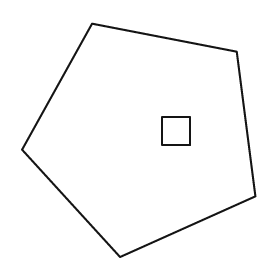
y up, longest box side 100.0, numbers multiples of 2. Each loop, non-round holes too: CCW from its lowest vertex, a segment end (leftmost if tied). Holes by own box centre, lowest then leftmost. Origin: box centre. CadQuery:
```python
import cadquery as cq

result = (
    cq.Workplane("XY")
    .moveTo(-8.0, -50.0)
    .lineTo(50.0, -24.0)
    .lineTo(42.0, 38.0)
    .lineTo(-20.0, 50.0)
    .lineTo(-50.0, -4.0)
    .close()
    .moveTo(10.0, -2.0)
    .lineTo(22.0, -2.0)
    .lineTo(22.0, 10.0)
    .lineTo(10.0, 10.0)
    .close()
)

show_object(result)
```